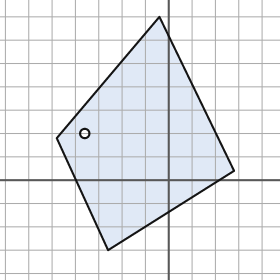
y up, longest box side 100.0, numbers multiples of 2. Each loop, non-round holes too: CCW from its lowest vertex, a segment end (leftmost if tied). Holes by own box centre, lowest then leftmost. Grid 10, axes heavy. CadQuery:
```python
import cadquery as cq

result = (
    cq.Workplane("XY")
    .moveTo(-26.0, -30.0)
    .lineTo(28.0, 4.0)
    .lineTo(-4.0, 70.0)
    .lineTo(-48.0, 18.0)
    .close()
    .moveTo(-36.0, 20.0)
    .circle(2.0)
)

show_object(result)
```